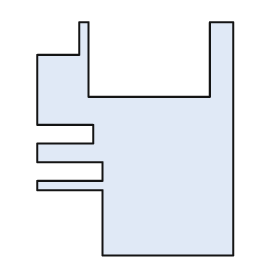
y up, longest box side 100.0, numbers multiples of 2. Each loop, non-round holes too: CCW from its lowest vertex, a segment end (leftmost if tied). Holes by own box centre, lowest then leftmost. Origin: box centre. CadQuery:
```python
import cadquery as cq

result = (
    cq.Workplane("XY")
    .moveTo(-14.0, -50.0)
    .lineTo(42.0, -50.0)
    .lineTo(42.0, 50.0)
    .lineTo(32.0, 50.0)
    .lineTo(32.0, 18.0)
    .lineTo(-20.0, 18.0)
    .lineTo(-20.0, 50.0)
    .lineTo(-24.0, 50.0)
    .lineTo(-24.0, 36.0)
    .lineTo(-42.0, 36.0)
    .lineTo(-42.0, 6.0)
    .lineTo(-18.0, 6.0)
    .lineTo(-18.0, -2.0)
    .lineTo(-42.0, -2.0)
    .lineTo(-42.0, -10.0)
    .lineTo(-14.0, -10.0)
    .lineTo(-14.0, -18.0)
    .lineTo(-42.0, -18.0)
    .lineTo(-42.0, -22.0)
    .lineTo(-14.0, -22.0)
    .close()
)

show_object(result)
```